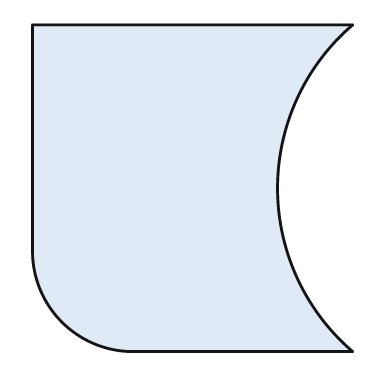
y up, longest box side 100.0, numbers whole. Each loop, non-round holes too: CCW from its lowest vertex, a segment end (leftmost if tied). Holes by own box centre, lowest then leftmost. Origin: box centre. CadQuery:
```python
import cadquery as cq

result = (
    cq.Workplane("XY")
    .moveTo(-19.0, -50.0)
    .lineTo(49.0, -50.0)
    .threePointArc((26.0, 0.0), (49.0, 50.0))
    .lineTo(-49.0, 50.0)
    .lineTo(-49.0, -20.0)
    .threePointArc((-40.0, -41.0), (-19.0, -50.0))
    .close()
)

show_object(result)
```